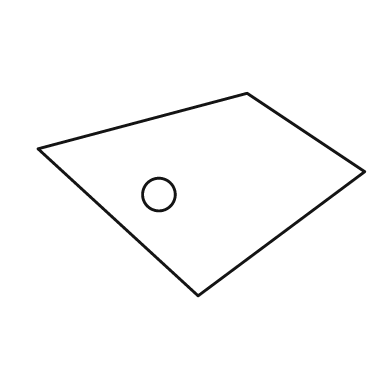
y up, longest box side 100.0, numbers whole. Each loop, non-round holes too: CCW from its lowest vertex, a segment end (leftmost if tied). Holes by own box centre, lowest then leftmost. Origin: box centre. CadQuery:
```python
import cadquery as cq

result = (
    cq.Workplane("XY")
    .moveTo(-1.0, -31.0)
    .lineTo(50.0, 7.0)
    .lineTo(14.0, 31.0)
    .lineTo(-50.0, 14.0)
    .close()
    .moveTo(-13.0, 0.0)
    .circle(5.0)
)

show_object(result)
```